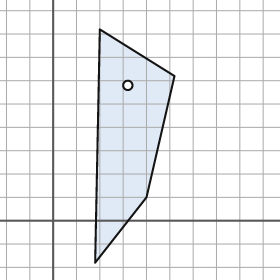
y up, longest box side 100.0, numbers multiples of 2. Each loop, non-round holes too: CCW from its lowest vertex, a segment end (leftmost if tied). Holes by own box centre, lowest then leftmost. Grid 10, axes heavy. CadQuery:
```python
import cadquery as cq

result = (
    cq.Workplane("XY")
    .moveTo(18.0, -18.0)
    .lineTo(40.0, 10.0)
    .lineTo(52.0, 62.0)
    .lineTo(20.0, 82.0)
    .close()
    .moveTo(32.0, 58.0)
    .circle(2.0)
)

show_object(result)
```